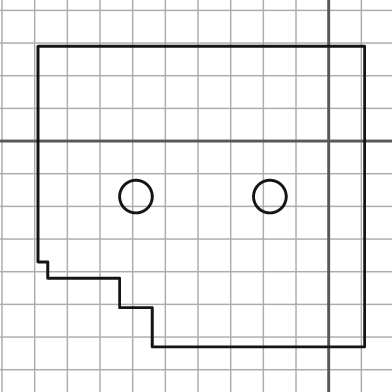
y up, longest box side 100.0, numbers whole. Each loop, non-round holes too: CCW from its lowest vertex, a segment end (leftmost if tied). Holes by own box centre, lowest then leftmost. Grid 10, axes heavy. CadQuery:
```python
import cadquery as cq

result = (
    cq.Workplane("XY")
    .moveTo(-54.0, -63.0)
    .lineTo(11.0, -63.0)
    .lineTo(11.0, 29.0)
    .lineTo(-89.0, 29.0)
    .lineTo(-89.0, -37.0)
    .lineTo(-86.0, -37.0)
    .lineTo(-86.0, -42.0)
    .lineTo(-64.0, -42.0)
    .lineTo(-64.0, -51.0)
    .lineTo(-54.0, -51.0)
    .close()
    .moveTo(-59.0, -17.0)
    .circle(5.0)
    .moveTo(-18.0, -17.0)
    .circle(5.0)
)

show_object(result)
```